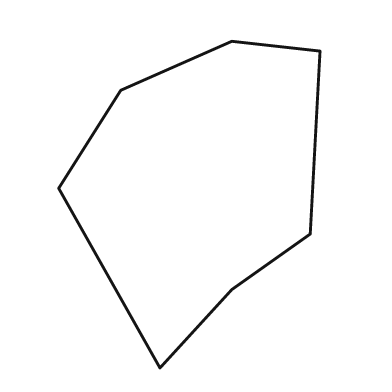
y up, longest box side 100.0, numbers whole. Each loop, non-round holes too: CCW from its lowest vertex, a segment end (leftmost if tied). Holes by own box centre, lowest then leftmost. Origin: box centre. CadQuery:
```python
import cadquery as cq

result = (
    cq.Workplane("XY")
    .moveTo(-9.0, -50.0)
    .lineTo(13.0, -26.0)
    .lineTo(37.0, -9.0)
    .lineTo(40.0, 47.0)
    .lineTo(13.0, 50.0)
    .lineTo(-21.0, 35.0)
    .lineTo(-40.0, 5.0)
    .close()
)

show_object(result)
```